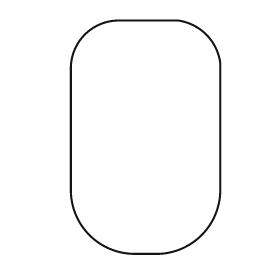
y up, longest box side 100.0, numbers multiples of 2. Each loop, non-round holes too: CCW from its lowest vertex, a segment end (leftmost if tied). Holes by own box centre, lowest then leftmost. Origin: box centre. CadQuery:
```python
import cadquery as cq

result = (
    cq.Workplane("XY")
    .moveTo(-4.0, -50.0)
    .lineTo(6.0, -50.0)
    .threePointArc((24.0, -42.0), (32.0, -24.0))
    .lineTo(32.0, 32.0)
    .threePointArc((26.0, 44.0), (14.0, 50.0))
    .lineTo(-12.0, 50.0)
    .threePointArc((-26.0, 44.0), (-32.0, 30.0))
    .lineTo(-32.0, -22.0)
    .threePointArc((-24.0, -42.0), (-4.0, -50.0))
    .close()
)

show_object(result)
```